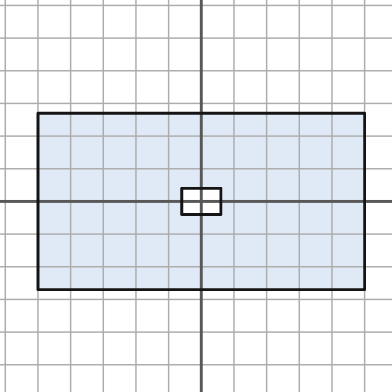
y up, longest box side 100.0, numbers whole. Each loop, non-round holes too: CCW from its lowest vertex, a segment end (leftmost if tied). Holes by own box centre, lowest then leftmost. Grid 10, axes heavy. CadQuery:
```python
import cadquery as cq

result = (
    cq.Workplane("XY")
    .moveTo(-50.0, -27.0)
    .lineTo(50.0, -27.0)
    .lineTo(50.0, 27.0)
    .lineTo(-50.0, 27.0)
    .close()
    .moveTo(-6.0, -4.0)
    .lineTo(6.0, -4.0)
    .lineTo(6.0, 4.0)
    .lineTo(-6.0, 4.0)
    .close()
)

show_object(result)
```